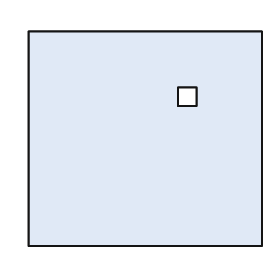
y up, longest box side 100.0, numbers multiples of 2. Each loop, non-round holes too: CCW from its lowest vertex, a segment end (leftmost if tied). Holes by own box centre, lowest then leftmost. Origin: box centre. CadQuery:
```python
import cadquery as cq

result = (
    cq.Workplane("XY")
    .moveTo(-50.0, -46.0)
    .lineTo(50.0, -46.0)
    .lineTo(50.0, 46.0)
    .lineTo(-50.0, 46.0)
    .close()
    .moveTo(14.0, 14.0)
    .lineTo(22.0, 14.0)
    .lineTo(22.0, 22.0)
    .lineTo(14.0, 22.0)
    .close()
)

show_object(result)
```